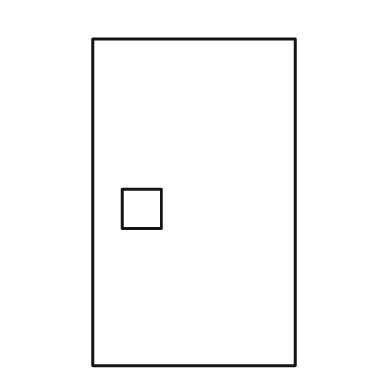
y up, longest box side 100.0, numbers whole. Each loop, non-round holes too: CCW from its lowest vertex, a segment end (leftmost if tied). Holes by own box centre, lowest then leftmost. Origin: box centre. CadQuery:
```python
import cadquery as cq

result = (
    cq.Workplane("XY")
    .moveTo(-31.0, -50.0)
    .lineTo(31.0, -50.0)
    .lineTo(31.0, 50.0)
    .lineTo(-31.0, 50.0)
    .close()
    .moveTo(-22.0, -8.0)
    .lineTo(-10.0, -8.0)
    .lineTo(-10.0, 4.0)
    .lineTo(-22.0, 4.0)
    .close()
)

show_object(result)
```